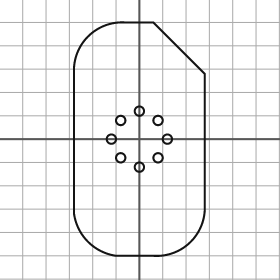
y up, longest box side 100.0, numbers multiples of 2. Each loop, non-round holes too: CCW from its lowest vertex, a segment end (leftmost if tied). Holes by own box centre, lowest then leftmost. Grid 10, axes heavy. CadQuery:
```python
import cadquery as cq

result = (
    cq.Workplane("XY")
    .moveTo(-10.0, -50.0)
    .lineTo(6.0, -50.0)
    .threePointArc((22.0, -44.0), (28.0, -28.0))
    .lineTo(28.0, 28.0)
    .lineTo(6.0, 50.0)
    .lineTo(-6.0, 50.0)
    .threePointArc((-22.0, 44.0), (-28.0, 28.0))
    .lineTo(-28.0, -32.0)
    .threePointArc((-22.0, -44.0), (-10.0, -50.0))
    .close()
    .moveTo(0.0, -12.0)
    .circle(2.0)
    .moveTo(-8.0, -8.0)
    .circle(2.0)
    .moveTo(8.0, -8.0)
    .circle(2.0)
    .moveTo(-12.0, 0.0)
    .circle(2.0)
    .moveTo(12.0, 0.0)
    .circle(2.0)
    .moveTo(-8.0, 8.0)
    .circle(2.0)
    .moveTo(8.0, 8.0)
    .circle(2.0)
    .moveTo(0.0, 12.0)
    .circle(2.0)
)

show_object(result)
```